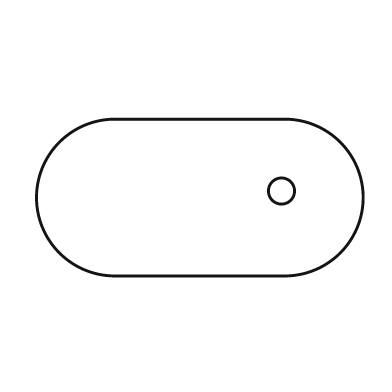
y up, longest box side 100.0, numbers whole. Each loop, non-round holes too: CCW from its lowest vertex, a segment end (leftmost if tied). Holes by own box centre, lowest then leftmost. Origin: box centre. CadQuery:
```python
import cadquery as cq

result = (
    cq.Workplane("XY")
    .moveTo(-26.0, -24.0)
    .lineTo(26.0, -24.0)
    .threePointArc((50.0, 0.0), (26.0, 24.0))
    .lineTo(-26.0, 24.0)
    .threePointArc((-50.0, 0.0), (-26.0, -24.0))
    .close()
    .moveTo(25.0, 2.0)
    .circle(4.0)
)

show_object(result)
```